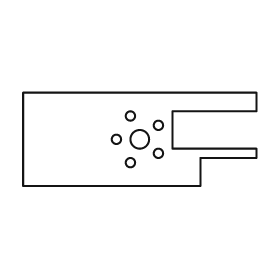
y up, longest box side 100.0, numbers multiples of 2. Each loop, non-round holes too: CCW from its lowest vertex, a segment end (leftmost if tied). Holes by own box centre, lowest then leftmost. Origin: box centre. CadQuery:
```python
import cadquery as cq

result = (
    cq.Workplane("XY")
    .moveTo(-50.0, -20.0)
    .lineTo(26.0, -20.0)
    .lineTo(26.0, -8.0)
    .lineTo(50.0, -8.0)
    .lineTo(50.0, -4.0)
    .lineTo(14.0, -4.0)
    .lineTo(14.0, 12.0)
    .lineTo(50.0, 12.0)
    .lineTo(50.0, 20.0)
    .lineTo(-50.0, 20.0)
    .close()
    .moveTo(-4.0, -10.0)
    .circle(2.0)
    .moveTo(8.0, -6.0)
    .circle(2.0)
    .moveTo(-10.0, 0.0)
    .circle(2.0)
    .moveTo(0.0, 0.0)
    .circle(4.0)
    .moveTo(8.0, 6.0)
    .circle(2.0)
    .moveTo(-4.0, 10.0)
    .circle(2.0)
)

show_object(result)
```